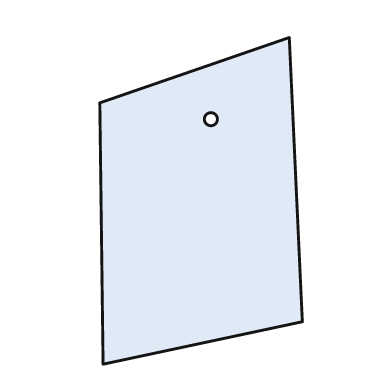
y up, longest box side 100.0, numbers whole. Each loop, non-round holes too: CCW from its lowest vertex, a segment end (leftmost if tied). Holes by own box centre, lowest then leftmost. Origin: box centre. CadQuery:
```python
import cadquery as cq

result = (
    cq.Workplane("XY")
    .moveTo(-30.0, -50.0)
    .lineTo(31.0, -37.0)
    .lineTo(27.0, 50.0)
    .lineTo(-31.0, 30.0)
    .close()
    .moveTo(3.0, 25.0)
    .circle(2.0)
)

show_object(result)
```